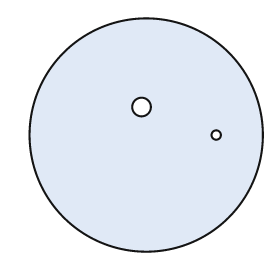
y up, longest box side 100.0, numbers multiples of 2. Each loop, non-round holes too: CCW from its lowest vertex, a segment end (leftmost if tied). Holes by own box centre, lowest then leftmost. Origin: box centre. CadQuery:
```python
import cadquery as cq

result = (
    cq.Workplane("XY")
    .moveTo(0.0, 0.0)
    .circle(50.0)
    .moveTo(30.0, 0.0)
    .circle(2.0)
    .moveTo(-2.0, 12.0)
    .circle(4.0)
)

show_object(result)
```